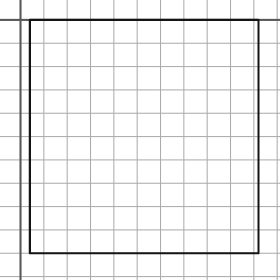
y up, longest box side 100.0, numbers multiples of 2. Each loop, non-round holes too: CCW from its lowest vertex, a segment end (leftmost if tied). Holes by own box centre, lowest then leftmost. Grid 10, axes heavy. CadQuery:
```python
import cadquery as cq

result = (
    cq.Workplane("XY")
    .moveTo(4.0, -100.0)
    .lineTo(102.0, -100.0)
    .lineTo(102.0, 0.0)
    .lineTo(4.0, 0.0)
    .close()
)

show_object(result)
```